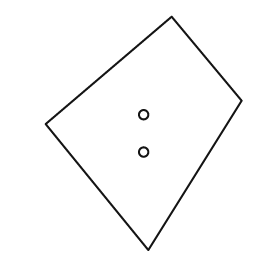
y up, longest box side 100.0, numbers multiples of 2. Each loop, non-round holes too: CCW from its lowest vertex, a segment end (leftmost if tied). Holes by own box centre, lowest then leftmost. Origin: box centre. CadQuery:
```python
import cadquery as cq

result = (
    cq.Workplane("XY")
    .moveTo(2.0, -50.0)
    .lineTo(42.0, 14.0)
    .lineTo(12.0, 50.0)
    .lineTo(-42.0, 4.0)
    .close()
    .moveTo(0.0, -8.0)
    .circle(2.0)
    .moveTo(0.0, 8.0)
    .circle(2.0)
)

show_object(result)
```